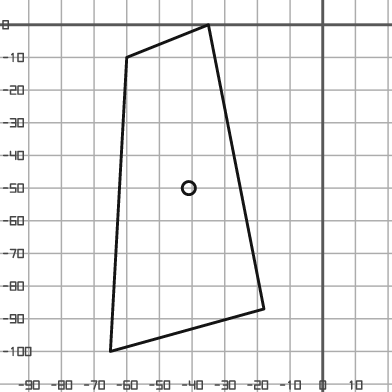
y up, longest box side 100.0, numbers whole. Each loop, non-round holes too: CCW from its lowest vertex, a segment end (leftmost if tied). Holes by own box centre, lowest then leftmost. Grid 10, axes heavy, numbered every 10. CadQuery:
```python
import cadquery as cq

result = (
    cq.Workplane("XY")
    .moveTo(-65.0, -100.0)
    .lineTo(-18.0, -87.0)
    .lineTo(-35.0, 0.0)
    .lineTo(-60.0, -10.0)
    .close()
    .moveTo(-41.0, -50.0)
    .circle(2.0)
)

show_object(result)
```